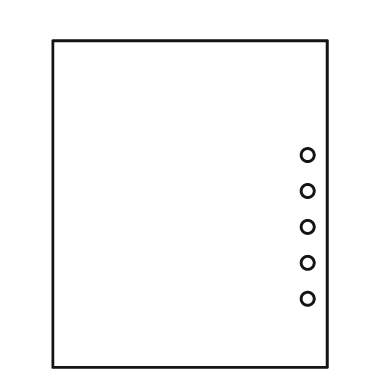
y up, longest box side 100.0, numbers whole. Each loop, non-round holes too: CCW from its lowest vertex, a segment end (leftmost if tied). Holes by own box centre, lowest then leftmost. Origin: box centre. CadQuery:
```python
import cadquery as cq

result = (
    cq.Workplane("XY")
    .moveTo(-42.0, -50.0)
    .lineTo(42.0, -50.0)
    .lineTo(42.0, 50.0)
    .lineTo(-42.0, 50.0)
    .close()
    .moveTo(36.0, -29.0)
    .circle(2.0)
    .moveTo(36.0, -18.0)
    .circle(2.0)
    .moveTo(36.0, -7.0)
    .circle(2.0)
    .moveTo(36.0, 4.0)
    .circle(2.0)
    .moveTo(36.0, 15.0)
    .circle(2.0)
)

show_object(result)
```